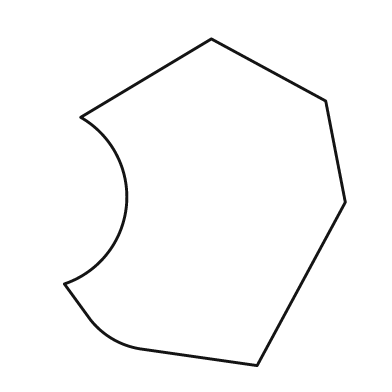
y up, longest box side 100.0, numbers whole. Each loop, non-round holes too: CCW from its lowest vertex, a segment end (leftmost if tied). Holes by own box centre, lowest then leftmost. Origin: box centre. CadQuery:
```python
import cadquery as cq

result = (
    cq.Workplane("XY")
    .moveTo(16.0, -50.0)
    .lineTo(43.0, 0.0)
    .lineTo(37.0, 31.0)
    .lineTo(2.0, 50.0)
    .lineTo(-38.0, 26.0)
    .threePointArc((-24.0, -1.0), (-43.0, -25.0))
    .lineTo(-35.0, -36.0)
    .threePointArc((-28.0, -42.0), (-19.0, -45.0))
    .close()
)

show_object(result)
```